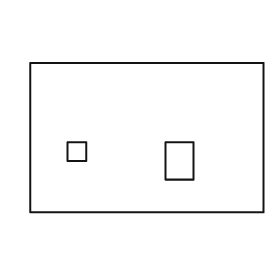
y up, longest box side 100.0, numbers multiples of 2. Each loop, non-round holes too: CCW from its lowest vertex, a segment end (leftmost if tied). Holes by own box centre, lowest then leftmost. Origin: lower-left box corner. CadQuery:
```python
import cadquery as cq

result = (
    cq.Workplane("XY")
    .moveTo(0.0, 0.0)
    .lineTo(100.0, 0.0)
    .lineTo(100.0, 64.0)
    .lineTo(0.0, 64.0)
    .close()
    .moveTo(58.0, 14.0)
    .lineTo(70.0, 14.0)
    .lineTo(70.0, 30.0)
    .lineTo(58.0, 30.0)
    .close()
    .moveTo(16.0, 22.0)
    .lineTo(24.0, 22.0)
    .lineTo(24.0, 30.0)
    .lineTo(16.0, 30.0)
    .close()
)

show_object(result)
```